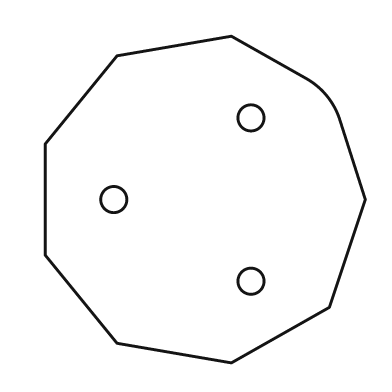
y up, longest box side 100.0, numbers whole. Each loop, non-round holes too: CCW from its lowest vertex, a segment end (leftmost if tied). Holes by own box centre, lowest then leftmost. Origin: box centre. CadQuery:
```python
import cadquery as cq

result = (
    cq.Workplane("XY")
    .moveTo(8.0, -50.0)
    .lineTo(38.0, -33.0)
    .lineTo(49.0, 0.0)
    .lineTo(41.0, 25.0)
    .threePointArc((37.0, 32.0), (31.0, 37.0))
    .lineTo(8.0, 50.0)
    .lineTo(-27.0, 44.0)
    .lineTo(-49.0, 17.0)
    .lineTo(-49.0, -17.0)
    .lineTo(-27.0, -44.0)
    .close()
    .moveTo(14.0, -25.0)
    .circle(4.0)
    .moveTo(-28.0, 0.0)
    .circle(4.0)
    .moveTo(14.0, 25.0)
    .circle(4.0)
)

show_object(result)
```